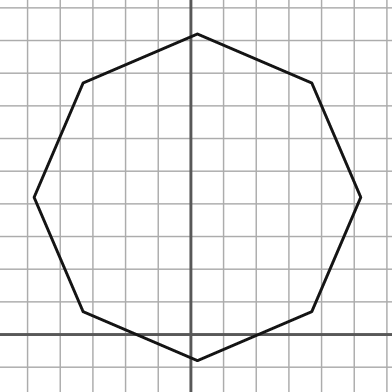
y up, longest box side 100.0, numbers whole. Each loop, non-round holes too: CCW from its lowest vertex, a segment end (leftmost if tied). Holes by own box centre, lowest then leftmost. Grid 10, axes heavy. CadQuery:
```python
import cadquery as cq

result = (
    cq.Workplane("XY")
    .moveTo(2.0, -8.0)
    .lineTo(37.0, 7.0)
    .lineTo(52.0, 42.0)
    .lineTo(37.0, 77.0)
    .lineTo(2.0, 92.0)
    .lineTo(-33.0, 77.0)
    .lineTo(-48.0, 42.0)
    .lineTo(-33.0, 7.0)
    .close()
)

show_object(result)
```